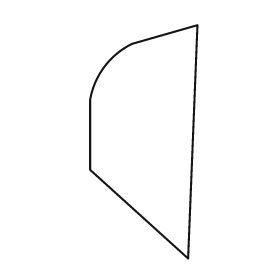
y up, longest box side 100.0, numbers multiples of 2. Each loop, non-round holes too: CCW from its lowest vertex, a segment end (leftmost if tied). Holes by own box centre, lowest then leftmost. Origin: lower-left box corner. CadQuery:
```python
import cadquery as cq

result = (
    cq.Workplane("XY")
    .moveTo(42.0, 0.0)
    .lineTo(46.0, 100.0)
    .lineTo(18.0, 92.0)
    .threePointArc((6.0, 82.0), (0.0, 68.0))
    .lineTo(0.0, 38.0)
    .close()
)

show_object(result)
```